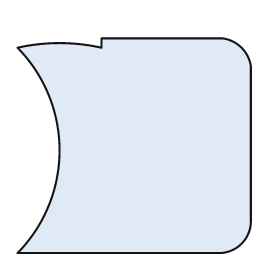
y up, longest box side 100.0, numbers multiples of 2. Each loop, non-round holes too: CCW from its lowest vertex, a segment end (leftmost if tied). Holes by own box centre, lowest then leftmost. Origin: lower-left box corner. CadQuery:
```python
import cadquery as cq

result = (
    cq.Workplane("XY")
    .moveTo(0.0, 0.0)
    .lineTo(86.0, 0.0)
    .threePointArc((96.0, 4.0), (100.0, 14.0))
    .lineTo(100.0, 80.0)
    .threePointArc((96.0, 88.0), (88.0, 92.0))
    .lineTo(36.0, 92.0)
    .lineTo(36.0, 88.0)
    .threePointArc((18.0, 90.0), (0.0, 88.0))
    .threePointArc((18.0, 44.0), (0.0, 0.0))
    .close()
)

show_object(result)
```